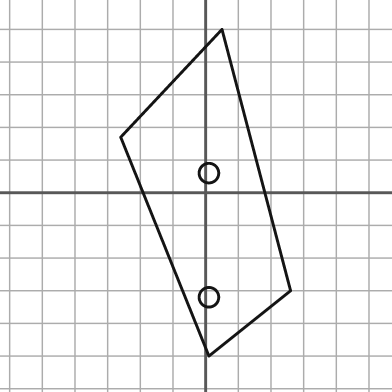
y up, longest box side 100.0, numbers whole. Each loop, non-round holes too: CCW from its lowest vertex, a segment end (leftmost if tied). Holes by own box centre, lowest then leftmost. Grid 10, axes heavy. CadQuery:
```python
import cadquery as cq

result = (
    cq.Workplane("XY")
    .moveTo(1.0, -50.0)
    .lineTo(26.0, -30.0)
    .lineTo(5.0, 50.0)
    .lineTo(-26.0, 17.0)
    .close()
    .moveTo(1.0, -32.0)
    .circle(3.0)
    .moveTo(1.0, 6.0)
    .circle(3.0)
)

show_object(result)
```